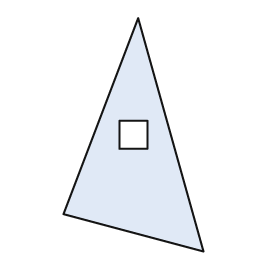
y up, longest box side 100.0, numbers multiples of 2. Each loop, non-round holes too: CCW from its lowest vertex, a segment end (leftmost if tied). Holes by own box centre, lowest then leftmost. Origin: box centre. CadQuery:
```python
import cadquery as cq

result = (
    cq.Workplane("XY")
    .moveTo(30.0, -50.0)
    .lineTo(2.0, 50.0)
    .lineTo(-30.0, -34.0)
    .close()
    .moveTo(-6.0, -6.0)
    .lineTo(6.0, -6.0)
    .lineTo(6.0, 6.0)
    .lineTo(-6.0, 6.0)
    .close()
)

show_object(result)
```